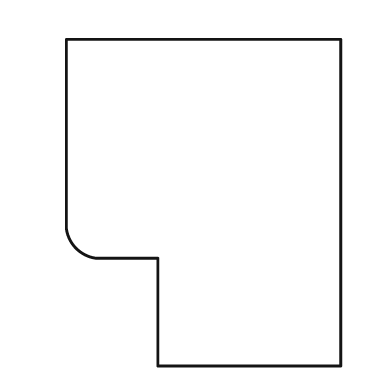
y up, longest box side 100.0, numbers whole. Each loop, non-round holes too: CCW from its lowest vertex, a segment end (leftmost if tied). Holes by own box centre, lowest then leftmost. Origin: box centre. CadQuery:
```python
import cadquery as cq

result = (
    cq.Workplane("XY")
    .moveTo(-14.0, -50.0)
    .lineTo(42.0, -50.0)
    .lineTo(42.0, 50.0)
    .lineTo(-42.0, 50.0)
    .lineTo(-42.0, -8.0)
    .threePointArc((-39.0, -14.0), (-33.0, -17.0))
    .lineTo(-14.0, -17.0)
    .close()
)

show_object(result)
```